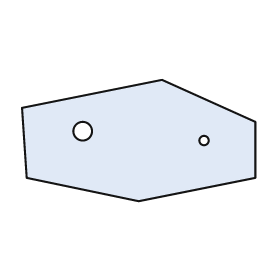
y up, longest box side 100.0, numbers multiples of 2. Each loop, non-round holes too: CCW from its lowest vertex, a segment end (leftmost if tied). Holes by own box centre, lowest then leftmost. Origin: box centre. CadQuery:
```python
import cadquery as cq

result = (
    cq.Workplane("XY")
    .moveTo(0.0, -26.0)
    .lineTo(50.0, -16.0)
    .lineTo(50.0, 8.0)
    .lineTo(10.0, 26.0)
    .lineTo(-50.0, 14.0)
    .lineTo(-48.0, -16.0)
    .close()
    .moveTo(28.0, 0.0)
    .circle(2.0)
    .moveTo(-24.0, 4.0)
    .circle(4.0)
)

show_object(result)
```